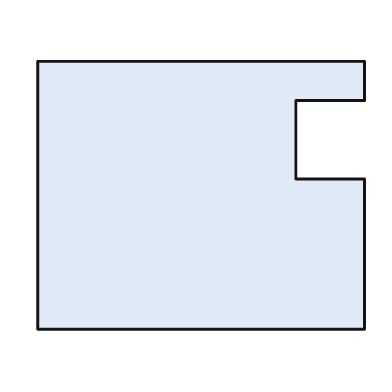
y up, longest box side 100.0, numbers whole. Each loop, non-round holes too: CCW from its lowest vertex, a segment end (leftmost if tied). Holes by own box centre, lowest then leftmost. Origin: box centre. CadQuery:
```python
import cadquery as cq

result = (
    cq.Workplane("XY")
    .moveTo(-50.0, -41.0)
    .lineTo(50.0, -41.0)
    .lineTo(50.0, 5.0)
    .lineTo(29.0, 5.0)
    .lineTo(29.0, 29.0)
    .lineTo(50.0, 29.0)
    .lineTo(50.0, 41.0)
    .lineTo(-50.0, 41.0)
    .close()
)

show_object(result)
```